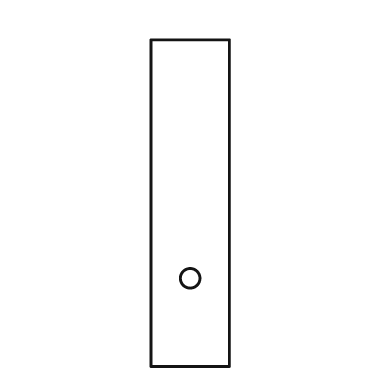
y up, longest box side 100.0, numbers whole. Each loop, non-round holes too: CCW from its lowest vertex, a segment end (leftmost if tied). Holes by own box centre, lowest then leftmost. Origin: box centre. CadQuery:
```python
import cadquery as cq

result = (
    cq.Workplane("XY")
    .moveTo(-12.0, -50.0)
    .lineTo(12.0, -50.0)
    .lineTo(12.0, 50.0)
    .lineTo(-12.0, 50.0)
    .close()
    .moveTo(0.0, -23.0)
    .circle(3.0)
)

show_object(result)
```